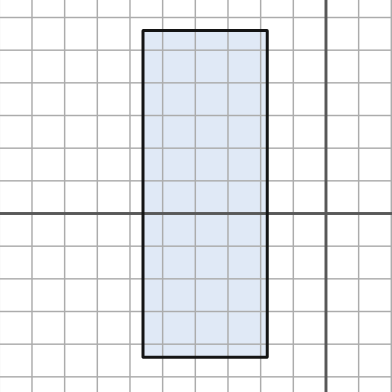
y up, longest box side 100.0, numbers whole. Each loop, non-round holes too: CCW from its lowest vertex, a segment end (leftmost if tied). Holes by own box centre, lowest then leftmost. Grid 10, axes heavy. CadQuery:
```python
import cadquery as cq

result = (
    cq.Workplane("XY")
    .moveTo(-56.0, -44.0)
    .lineTo(-18.0, -44.0)
    .lineTo(-18.0, 56.0)
    .lineTo(-56.0, 56.0)
    .close()
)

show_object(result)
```